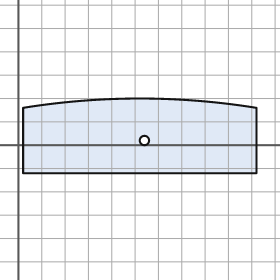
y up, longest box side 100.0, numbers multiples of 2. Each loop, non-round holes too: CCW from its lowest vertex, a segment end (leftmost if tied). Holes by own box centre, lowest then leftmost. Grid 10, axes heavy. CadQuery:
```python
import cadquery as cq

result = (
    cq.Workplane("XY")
    .moveTo(2.0, -12.0)
    .lineTo(102.0, -12.0)
    .lineTo(102.0, 16.0)
    .threePointArc((52.0, 20.0), (2.0, 16.0))
    .close()
    .moveTo(54.0, 2.0)
    .circle(2.0)
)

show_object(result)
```